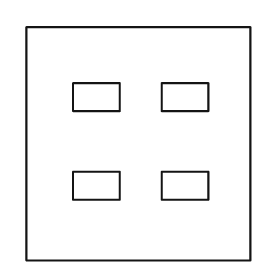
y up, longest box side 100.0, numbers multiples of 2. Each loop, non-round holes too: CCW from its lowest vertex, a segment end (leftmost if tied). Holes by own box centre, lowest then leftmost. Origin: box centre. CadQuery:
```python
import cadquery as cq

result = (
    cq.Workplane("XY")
    .moveTo(-48.0, -50.0)
    .lineTo(48.0, -50.0)
    .lineTo(48.0, 50.0)
    .lineTo(-48.0, 50.0)
    .close()
    .moveTo(-28.0, -24.0)
    .lineTo(-8.0, -24.0)
    .lineTo(-8.0, -12.0)
    .lineTo(-28.0, -12.0)
    .close()
    .moveTo(10.0, -24.0)
    .lineTo(30.0, -24.0)
    .lineTo(30.0, -12.0)
    .lineTo(10.0, -12.0)
    .close()
    .moveTo(-28.0, 14.0)
    .lineTo(-8.0, 14.0)
    .lineTo(-8.0, 26.0)
    .lineTo(-28.0, 26.0)
    .close()
    .moveTo(10.0, 14.0)
    .lineTo(30.0, 14.0)
    .lineTo(30.0, 26.0)
    .lineTo(10.0, 26.0)
    .close()
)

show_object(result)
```